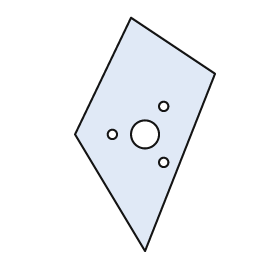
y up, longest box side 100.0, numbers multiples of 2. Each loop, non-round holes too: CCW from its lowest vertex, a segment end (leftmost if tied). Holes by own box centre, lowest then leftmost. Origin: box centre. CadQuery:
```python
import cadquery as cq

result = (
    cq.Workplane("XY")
    .moveTo(0.0, -50.0)
    .lineTo(30.0, 26.0)
    .lineTo(-6.0, 50.0)
    .lineTo(-30.0, 0.0)
    .close()
    .moveTo(8.0, -12.0)
    .circle(2.0)
    .moveTo(-14.0, 0.0)
    .circle(2.0)
    .moveTo(0.0, 0.0)
    .circle(6.0)
    .moveTo(8.0, 12.0)
    .circle(2.0)
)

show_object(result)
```